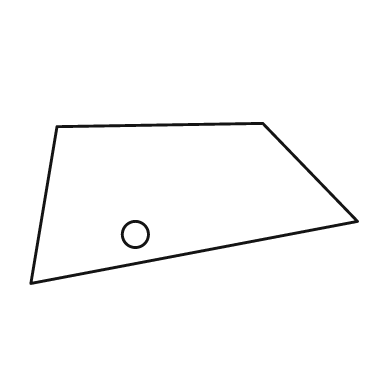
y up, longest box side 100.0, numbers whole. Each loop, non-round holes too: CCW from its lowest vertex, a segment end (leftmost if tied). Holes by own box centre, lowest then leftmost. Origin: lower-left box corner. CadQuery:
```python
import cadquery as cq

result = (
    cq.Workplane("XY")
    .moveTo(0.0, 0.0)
    .lineTo(100.0, 19.0)
    .lineTo(71.0, 49.0)
    .lineTo(8.0, 48.0)
    .close()
    .moveTo(32.0, 15.0)
    .circle(4.0)
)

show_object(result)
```